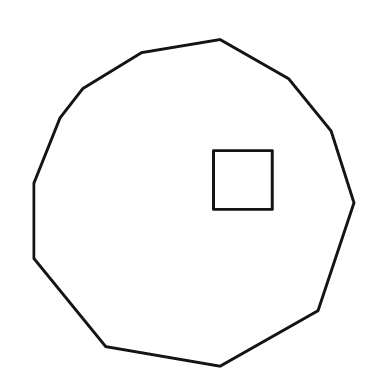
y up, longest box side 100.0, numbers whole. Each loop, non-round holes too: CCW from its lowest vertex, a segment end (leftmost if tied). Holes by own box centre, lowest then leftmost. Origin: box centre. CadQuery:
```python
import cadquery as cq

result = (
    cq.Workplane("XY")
    .moveTo(8.0, -50.0)
    .lineTo(38.0, -33.0)
    .lineTo(49.0, 0.0)
    .lineTo(42.0, 22.0)
    .lineTo(29.0, 38.0)
    .lineTo(8.0, 50.0)
    .lineTo(-16.0, 46.0)
    .lineTo(-34.0, 35.0)
    .lineTo(-41.0, 26.0)
    .lineTo(-49.0, 6.0)
    .lineTo(-49.0, -17.0)
    .lineTo(-27.0, -44.0)
    .close()
    .moveTo(6.0, -2.0)
    .lineTo(24.0, -2.0)
    .lineTo(24.0, 16.0)
    .lineTo(6.0, 16.0)
    .close()
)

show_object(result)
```